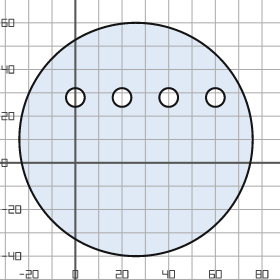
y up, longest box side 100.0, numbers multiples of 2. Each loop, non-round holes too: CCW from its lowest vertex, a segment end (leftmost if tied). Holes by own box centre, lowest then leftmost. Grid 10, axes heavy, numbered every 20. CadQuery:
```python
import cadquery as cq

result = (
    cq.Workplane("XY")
    .moveTo(26.0, 10.0)
    .circle(50.0)
    .moveTo(0.0, 28.0)
    .circle(4.0)
    .moveTo(20.0, 28.0)
    .circle(4.0)
    .moveTo(40.0, 28.0)
    .circle(4.0)
    .moveTo(60.0, 28.0)
    .circle(4.0)
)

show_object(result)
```